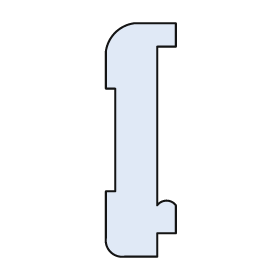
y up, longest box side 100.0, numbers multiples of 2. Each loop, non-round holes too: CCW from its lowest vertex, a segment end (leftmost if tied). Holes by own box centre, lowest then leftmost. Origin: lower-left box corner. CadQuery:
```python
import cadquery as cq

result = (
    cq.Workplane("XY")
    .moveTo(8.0, 0.0)
    .lineTo(22.0, 0.0)
    .lineTo(22.0, 10.0)
    .lineTo(30.0, 10.0)
    .lineTo(30.0, 22.0)
    .threePointArc((26.0, 24.0), (22.0, 22.0))
    .lineTo(22.0, 90.0)
    .lineTo(30.0, 90.0)
    .lineTo(30.0, 100.0)
    .lineTo(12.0, 100.0)
    .threePointArc((4.0, 96.0), (0.0, 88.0))
    .lineTo(0.0, 72.0)
    .lineTo(4.0, 72.0)
    .lineTo(4.0, 28.0)
    .lineTo(0.0, 28.0)
    .lineTo(0.0, 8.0)
    .threePointArc((2.0, 2.0), (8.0, 0.0))
    .close()
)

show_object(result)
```